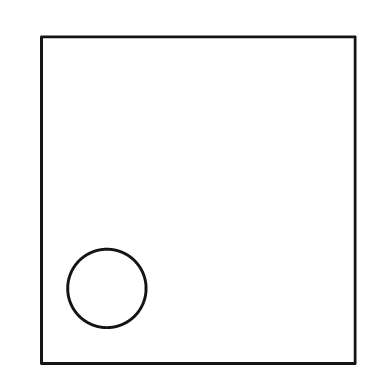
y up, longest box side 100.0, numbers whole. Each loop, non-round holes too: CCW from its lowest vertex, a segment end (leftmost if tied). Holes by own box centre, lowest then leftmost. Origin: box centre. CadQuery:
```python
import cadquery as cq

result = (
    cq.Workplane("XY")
    .moveTo(-48.0, -50.0)
    .lineTo(48.0, -50.0)
    .lineTo(48.0, 50.0)
    .lineTo(-48.0, 50.0)
    .close()
    .moveTo(-28.0, -27.0)
    .circle(12.0)
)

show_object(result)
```